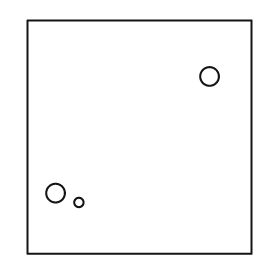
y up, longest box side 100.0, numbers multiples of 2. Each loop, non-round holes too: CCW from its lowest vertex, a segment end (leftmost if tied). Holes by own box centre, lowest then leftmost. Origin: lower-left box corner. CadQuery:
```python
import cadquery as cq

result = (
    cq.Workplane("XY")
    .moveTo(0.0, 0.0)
    .lineTo(96.0, 0.0)
    .lineTo(96.0, 100.0)
    .lineTo(0.0, 100.0)
    .close()
    .moveTo(22.0, 22.0)
    .circle(2.0)
    .moveTo(12.0, 26.0)
    .circle(4.0)
    .moveTo(78.0, 76.0)
    .circle(4.0)
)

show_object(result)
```